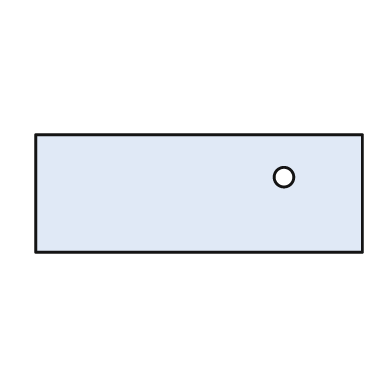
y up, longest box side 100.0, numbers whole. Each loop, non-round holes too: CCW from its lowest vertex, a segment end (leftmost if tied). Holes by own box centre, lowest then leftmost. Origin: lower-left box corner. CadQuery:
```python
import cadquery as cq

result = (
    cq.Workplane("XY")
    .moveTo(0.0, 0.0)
    .lineTo(100.0, 0.0)
    .lineTo(100.0, 36.0)
    .lineTo(0.0, 36.0)
    .close()
    .moveTo(76.0, 23.0)
    .circle(3.0)
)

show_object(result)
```